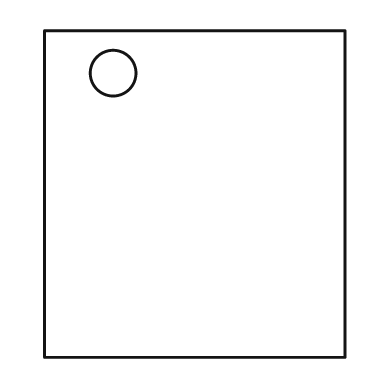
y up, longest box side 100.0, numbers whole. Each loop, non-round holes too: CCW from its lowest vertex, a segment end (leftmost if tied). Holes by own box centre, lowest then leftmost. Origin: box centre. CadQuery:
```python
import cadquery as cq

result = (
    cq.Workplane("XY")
    .moveTo(-46.0, -50.0)
    .lineTo(46.0, -50.0)
    .lineTo(46.0, 50.0)
    .lineTo(-46.0, 50.0)
    .close()
    .moveTo(-25.0, 37.0)
    .circle(7.0)
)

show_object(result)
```